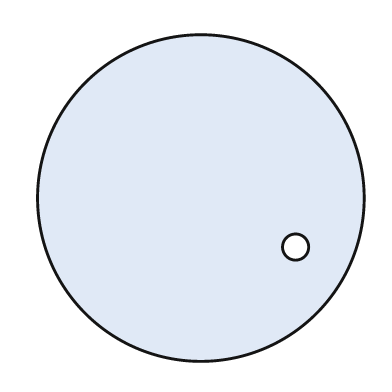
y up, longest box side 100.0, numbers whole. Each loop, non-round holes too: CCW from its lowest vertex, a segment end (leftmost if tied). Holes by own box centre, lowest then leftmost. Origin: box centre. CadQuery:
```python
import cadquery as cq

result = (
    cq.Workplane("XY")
    .moveTo(0.0, 0.0)
    .circle(50.0)
    .moveTo(29.0, -15.0)
    .circle(4.0)
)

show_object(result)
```